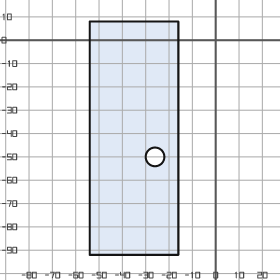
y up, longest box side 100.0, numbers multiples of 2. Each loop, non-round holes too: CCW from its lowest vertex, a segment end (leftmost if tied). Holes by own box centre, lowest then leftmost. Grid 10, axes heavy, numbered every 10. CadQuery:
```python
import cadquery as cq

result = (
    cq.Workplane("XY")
    .moveTo(-54.0, -92.0)
    .lineTo(-16.0, -92.0)
    .lineTo(-16.0, 8.0)
    .lineTo(-54.0, 8.0)
    .close()
    .moveTo(-26.0, -50.0)
    .circle(4.0)
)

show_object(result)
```